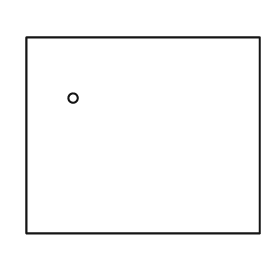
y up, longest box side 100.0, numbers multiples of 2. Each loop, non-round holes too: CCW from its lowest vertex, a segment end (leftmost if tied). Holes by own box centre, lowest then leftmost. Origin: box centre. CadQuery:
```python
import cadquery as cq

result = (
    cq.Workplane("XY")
    .moveTo(-50.0, -42.0)
    .lineTo(50.0, -42.0)
    .lineTo(50.0, 42.0)
    .lineTo(-50.0, 42.0)
    .close()
    .moveTo(-30.0, 16.0)
    .circle(2.0)
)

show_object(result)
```